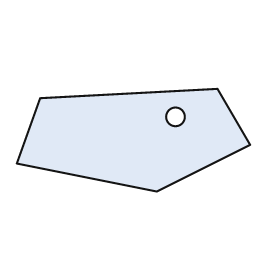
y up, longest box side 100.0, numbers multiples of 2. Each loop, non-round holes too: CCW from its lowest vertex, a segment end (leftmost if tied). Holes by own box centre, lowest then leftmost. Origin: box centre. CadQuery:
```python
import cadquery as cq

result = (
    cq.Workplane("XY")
    .moveTo(10.0, -22.0)
    .lineTo(50.0, -2.0)
    .lineTo(36.0, 22.0)
    .lineTo(-40.0, 18.0)
    .lineTo(-50.0, -10.0)
    .close()
    .moveTo(18.0, 10.0)
    .circle(4.0)
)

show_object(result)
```